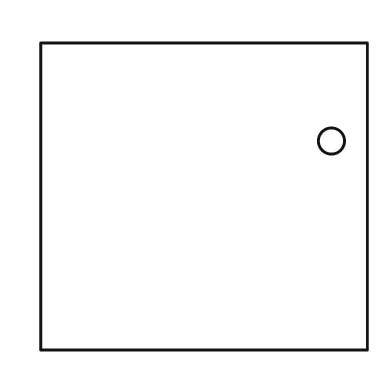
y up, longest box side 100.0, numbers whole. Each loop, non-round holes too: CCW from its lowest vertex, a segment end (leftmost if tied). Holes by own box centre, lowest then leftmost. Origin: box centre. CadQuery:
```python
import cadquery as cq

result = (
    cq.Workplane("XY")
    .moveTo(-50.0, -47.0)
    .lineTo(50.0, -47.0)
    .lineTo(50.0, 47.0)
    .lineTo(-50.0, 47.0)
    .close()
    .moveTo(39.0, 17.0)
    .circle(4.0)
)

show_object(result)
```